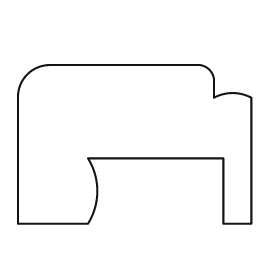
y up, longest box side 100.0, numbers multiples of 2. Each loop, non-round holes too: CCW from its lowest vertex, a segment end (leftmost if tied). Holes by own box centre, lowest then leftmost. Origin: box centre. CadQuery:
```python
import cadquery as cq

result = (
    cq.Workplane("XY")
    .moveTo(-50.0, -34.0)
    .lineTo(-20.0, -34.0)
    .threePointArc((-16.0, -20.0), (-20.0, -6.0))
    .lineTo(38.0, -6.0)
    .lineTo(38.0, -34.0)
    .lineTo(50.0, -34.0)
    .lineTo(50.0, 20.0)
    .threePointArc((42.0, 22.0), (34.0, 20.0))
    .lineTo(34.0, 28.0)
    .threePointArc((32.0, 32.0), (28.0, 34.0))
    .lineTo(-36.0, 34.0)
    .threePointArc((-46.0, 30.0), (-50.0, 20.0))
    .close()
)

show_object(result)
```